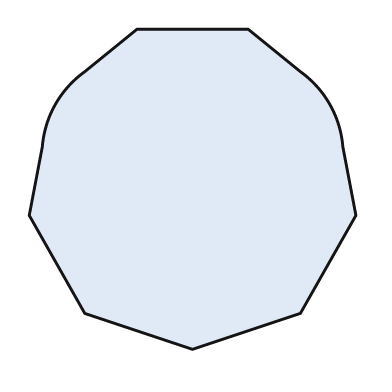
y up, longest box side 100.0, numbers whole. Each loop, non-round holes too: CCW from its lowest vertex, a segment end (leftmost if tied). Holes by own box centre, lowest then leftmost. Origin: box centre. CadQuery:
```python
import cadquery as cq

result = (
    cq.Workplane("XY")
    .moveTo(0.0, -49.0)
    .lineTo(33.0, -38.0)
    .lineTo(50.0, -8.0)
    .lineTo(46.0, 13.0)
    .threePointArc((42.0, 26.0), (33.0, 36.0))
    .lineTo(17.0, 49.0)
    .lineTo(-17.0, 49.0)
    .lineTo(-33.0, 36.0)
    .threePointArc((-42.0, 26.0), (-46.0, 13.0))
    .lineTo(-50.0, -8.0)
    .lineTo(-33.0, -38.0)
    .close()
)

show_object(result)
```